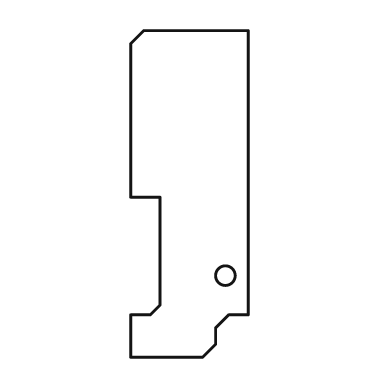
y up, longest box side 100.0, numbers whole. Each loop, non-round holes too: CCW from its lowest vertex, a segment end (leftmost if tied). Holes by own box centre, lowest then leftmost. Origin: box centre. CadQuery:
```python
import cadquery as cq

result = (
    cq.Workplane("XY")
    .moveTo(-18.0, -50.0)
    .lineTo(4.0, -50.0)
    .lineTo(8.0, -46.0)
    .lineTo(8.0, -41.0)
    .lineTo(12.0, -37.0)
    .lineTo(18.0, -37.0)
    .lineTo(18.0, 50.0)
    .lineTo(-14.0, 50.0)
    .lineTo(-18.0, 46.0)
    .lineTo(-18.0, -1.0)
    .lineTo(-9.0, -1.0)
    .lineTo(-9.0, -34.0)
    .lineTo(-12.0, -37.0)
    .lineTo(-18.0, -37.0)
    .close()
    .moveTo(11.0, -25.0)
    .circle(3.0)
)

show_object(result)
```